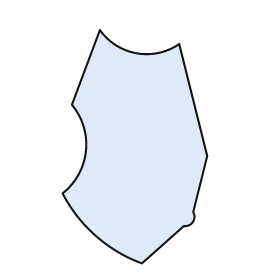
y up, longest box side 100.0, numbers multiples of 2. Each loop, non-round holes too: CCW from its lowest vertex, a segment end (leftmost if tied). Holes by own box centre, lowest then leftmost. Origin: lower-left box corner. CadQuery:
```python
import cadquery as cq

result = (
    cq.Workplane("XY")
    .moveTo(34.0, 0.0)
    .lineTo(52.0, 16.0)
    .threePointArc((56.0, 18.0), (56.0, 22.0))
    .lineTo(62.0, 46.0)
    .lineTo(50.0, 94.0)
    .threePointArc((32.0, 90.0), (16.0, 100.0))
    .lineTo(4.0, 68.0)
    .threePointArc((10.0, 48.0), (0.0, 30.0))
    .threePointArc((14.0, 12.0), (34.0, 0.0))
    .close()
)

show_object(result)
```